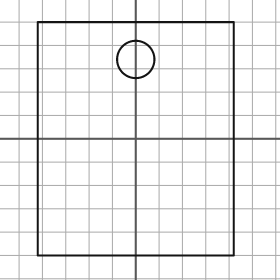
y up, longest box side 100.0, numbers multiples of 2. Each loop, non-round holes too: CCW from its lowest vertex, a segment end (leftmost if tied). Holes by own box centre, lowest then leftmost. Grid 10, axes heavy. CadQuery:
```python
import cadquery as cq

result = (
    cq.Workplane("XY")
    .moveTo(-42.0, -50.0)
    .lineTo(42.0, -50.0)
    .lineTo(42.0, 50.0)
    .lineTo(-42.0, 50.0)
    .close()
    .moveTo(0.0, 34.0)
    .circle(8.0)
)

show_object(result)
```